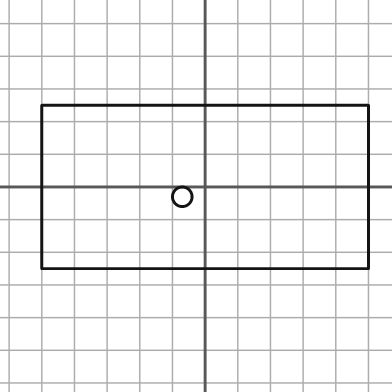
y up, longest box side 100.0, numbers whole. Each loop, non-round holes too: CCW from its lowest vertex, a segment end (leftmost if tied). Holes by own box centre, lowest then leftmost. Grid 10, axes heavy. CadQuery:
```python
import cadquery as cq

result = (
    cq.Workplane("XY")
    .moveTo(-50.0, -25.0)
    .lineTo(50.0, -25.0)
    .lineTo(50.0, 25.0)
    .lineTo(-50.0, 25.0)
    .close()
    .moveTo(-7.0, -3.0)
    .circle(3.0)
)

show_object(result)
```